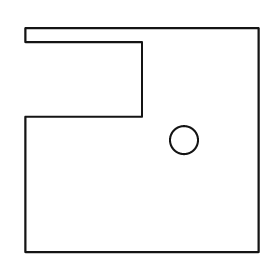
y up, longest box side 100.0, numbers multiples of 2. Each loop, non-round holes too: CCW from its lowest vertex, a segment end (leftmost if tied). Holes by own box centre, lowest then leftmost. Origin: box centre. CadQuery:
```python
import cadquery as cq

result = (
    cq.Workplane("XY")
    .moveTo(-50.0, -48.0)
    .lineTo(50.0, -48.0)
    .lineTo(50.0, 48.0)
    .lineTo(-50.0, 48.0)
    .lineTo(-50.0, 42.0)
    .lineTo(0.0, 42.0)
    .lineTo(0.0, 10.0)
    .lineTo(-50.0, 10.0)
    .close()
    .moveTo(18.0, 0.0)
    .circle(6.0)
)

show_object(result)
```